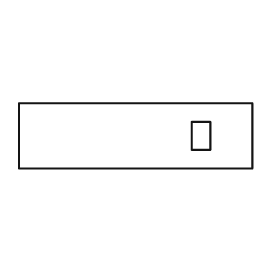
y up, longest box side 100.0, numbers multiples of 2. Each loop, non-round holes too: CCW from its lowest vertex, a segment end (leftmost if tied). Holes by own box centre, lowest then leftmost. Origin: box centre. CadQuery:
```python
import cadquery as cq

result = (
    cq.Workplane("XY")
    .moveTo(-50.0, -14.0)
    .lineTo(50.0, -14.0)
    .lineTo(50.0, 14.0)
    .lineTo(-50.0, 14.0)
    .close()
    .moveTo(24.0, -6.0)
    .lineTo(32.0, -6.0)
    .lineTo(32.0, 6.0)
    .lineTo(24.0, 6.0)
    .close()
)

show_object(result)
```